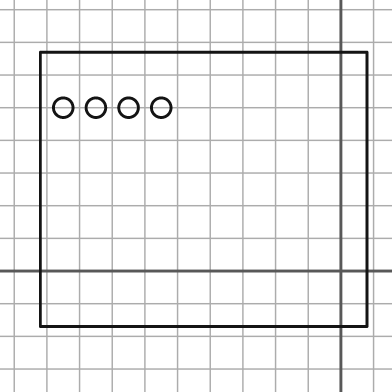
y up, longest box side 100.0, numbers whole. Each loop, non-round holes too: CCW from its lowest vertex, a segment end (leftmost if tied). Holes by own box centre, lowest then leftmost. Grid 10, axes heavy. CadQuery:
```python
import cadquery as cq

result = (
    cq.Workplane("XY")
    .moveTo(-92.0, -17.0)
    .lineTo(8.0, -17.0)
    .lineTo(8.0, 67.0)
    .lineTo(-92.0, 67.0)
    .close()
    .moveTo(-85.0, 50.0)
    .circle(3.0)
    .moveTo(-75.0, 50.0)
    .circle(3.0)
    .moveTo(-65.0, 50.0)
    .circle(3.0)
    .moveTo(-55.0, 50.0)
    .circle(3.0)
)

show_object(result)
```